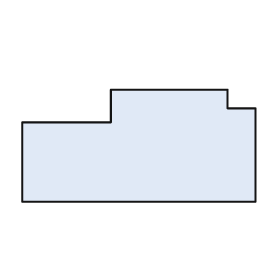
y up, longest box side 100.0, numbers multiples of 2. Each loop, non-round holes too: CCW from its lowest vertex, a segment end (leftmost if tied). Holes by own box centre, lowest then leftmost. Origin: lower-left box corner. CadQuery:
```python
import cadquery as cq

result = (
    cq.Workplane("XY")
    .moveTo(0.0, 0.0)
    .lineTo(100.0, 0.0)
    .lineTo(100.0, 40.0)
    .lineTo(88.0, 40.0)
    .lineTo(88.0, 48.0)
    .lineTo(38.0, 48.0)
    .lineTo(38.0, 34.0)
    .lineTo(0.0, 34.0)
    .close()
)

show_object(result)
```